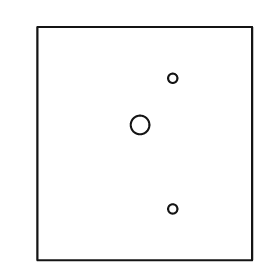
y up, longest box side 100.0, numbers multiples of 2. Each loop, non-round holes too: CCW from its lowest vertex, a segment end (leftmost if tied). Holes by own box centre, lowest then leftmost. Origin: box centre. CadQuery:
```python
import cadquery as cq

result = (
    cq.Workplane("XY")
    .moveTo(-46.0, -50.0)
    .lineTo(46.0, -50.0)
    .lineTo(46.0, 50.0)
    .lineTo(-46.0, 50.0)
    .close()
    .moveTo(12.0, -28.0)
    .circle(2.0)
    .moveTo(-2.0, 8.0)
    .circle(4.0)
    .moveTo(12.0, 28.0)
    .circle(2.0)
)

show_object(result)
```